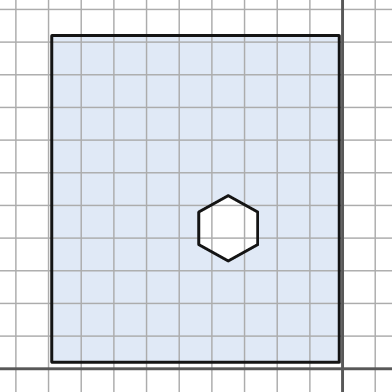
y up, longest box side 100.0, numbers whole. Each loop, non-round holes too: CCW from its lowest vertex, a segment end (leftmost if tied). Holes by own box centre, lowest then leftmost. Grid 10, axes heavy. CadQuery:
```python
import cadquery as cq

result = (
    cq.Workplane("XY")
    .moveTo(-89.0, 2.0)
    .lineTo(-1.0, 2.0)
    .lineTo(-1.0, 102.0)
    .lineTo(-89.0, 102.0)
    .close()
    .moveTo(-35.0, 33.0)
    .lineTo(-26.0, 38.0)
    .lineTo(-26.0, 48.0)
    .lineTo(-35.0, 53.0)
    .lineTo(-44.0, 48.0)
    .lineTo(-44.0, 38.0)
    .close()
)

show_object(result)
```